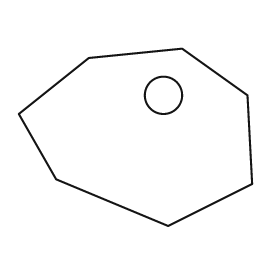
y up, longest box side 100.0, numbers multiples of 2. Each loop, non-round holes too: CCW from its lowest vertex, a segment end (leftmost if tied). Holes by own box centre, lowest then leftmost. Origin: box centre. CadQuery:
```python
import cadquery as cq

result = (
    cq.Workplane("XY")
    .moveTo(14.0, -38.0)
    .lineTo(50.0, -20.0)
    .lineTo(48.0, 18.0)
    .lineTo(20.0, 38.0)
    .lineTo(-20.0, 34.0)
    .lineTo(-50.0, 10.0)
    .lineTo(-34.0, -18.0)
    .close()
    .moveTo(12.0, 18.0)
    .circle(8.0)
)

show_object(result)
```